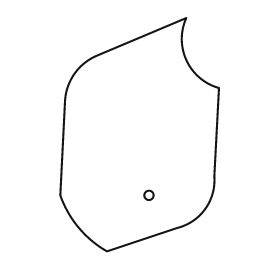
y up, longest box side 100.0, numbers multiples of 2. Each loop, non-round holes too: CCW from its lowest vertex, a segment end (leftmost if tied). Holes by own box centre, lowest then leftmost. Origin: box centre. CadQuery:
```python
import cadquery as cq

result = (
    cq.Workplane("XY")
    .moveTo(-14.0, -50.0)
    .lineTo(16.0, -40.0)
    .threePointArc((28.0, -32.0), (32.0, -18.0))
    .lineTo(34.0, 20.0)
    .threePointArc((20.0, 32.0), (20.0, 50.0))
    .lineTo(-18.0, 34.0)
    .threePointArc((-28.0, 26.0), (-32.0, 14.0))
    .lineTo(-34.0, -26.0)
    .threePointArc((-26.0, -40.0), (-14.0, -50.0))
    .close()
    .moveTo(4.0, -26.0)
    .circle(2.0)
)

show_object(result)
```